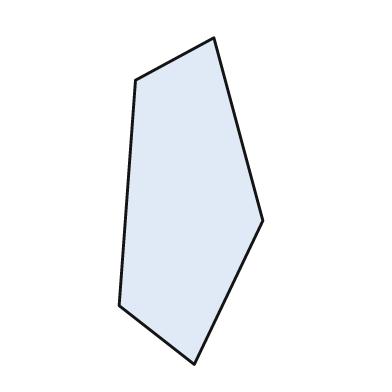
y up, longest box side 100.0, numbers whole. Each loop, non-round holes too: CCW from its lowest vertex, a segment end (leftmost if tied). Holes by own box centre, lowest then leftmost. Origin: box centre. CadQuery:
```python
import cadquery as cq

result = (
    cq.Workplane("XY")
    .moveTo(1.0, -50.0)
    .lineTo(22.0, -6.0)
    .lineTo(7.0, 50.0)
    .lineTo(-17.0, 37.0)
    .lineTo(-22.0, -32.0)
    .close()
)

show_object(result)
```